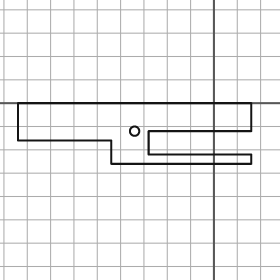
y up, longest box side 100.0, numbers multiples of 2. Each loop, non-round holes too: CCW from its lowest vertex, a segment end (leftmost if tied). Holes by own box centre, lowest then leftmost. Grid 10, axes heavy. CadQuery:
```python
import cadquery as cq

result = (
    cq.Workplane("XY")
    .moveTo(-44.0, -26.0)
    .lineTo(16.0, -26.0)
    .lineTo(16.0, -22.0)
    .lineTo(-28.0, -22.0)
    .lineTo(-28.0, -12.0)
    .lineTo(16.0, -12.0)
    .lineTo(16.0, 0.0)
    .lineTo(-84.0, 0.0)
    .lineTo(-84.0, -16.0)
    .lineTo(-44.0, -16.0)
    .close()
    .moveTo(-34.0, -12.0)
    .circle(2.0)
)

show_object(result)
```